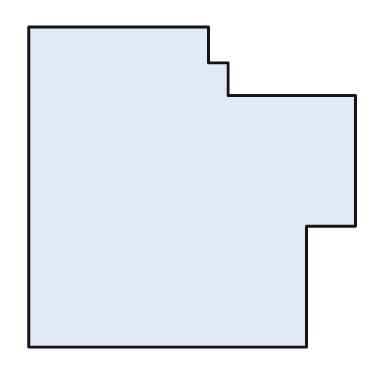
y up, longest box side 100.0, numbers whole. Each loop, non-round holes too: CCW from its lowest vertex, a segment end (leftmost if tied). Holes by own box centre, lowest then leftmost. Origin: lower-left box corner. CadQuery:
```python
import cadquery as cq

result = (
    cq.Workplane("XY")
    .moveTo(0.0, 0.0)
    .lineTo(85.0, 0.0)
    .lineTo(85.0, 37.0)
    .lineTo(100.0, 37.0)
    .lineTo(100.0, 77.0)
    .lineTo(61.0, 77.0)
    .lineTo(61.0, 87.0)
    .lineTo(55.0, 87.0)
    .lineTo(55.0, 98.0)
    .lineTo(0.0, 98.0)
    .close()
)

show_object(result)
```